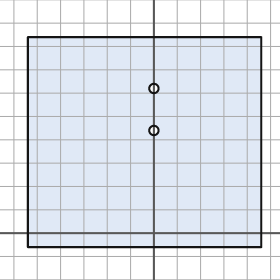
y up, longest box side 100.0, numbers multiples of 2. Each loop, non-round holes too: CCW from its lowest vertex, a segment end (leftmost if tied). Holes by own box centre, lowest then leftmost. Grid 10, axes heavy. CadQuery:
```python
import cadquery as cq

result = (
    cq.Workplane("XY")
    .moveTo(-54.0, -6.0)
    .lineTo(46.0, -6.0)
    .lineTo(46.0, 84.0)
    .lineTo(-54.0, 84.0)
    .close()
    .moveTo(0.0, 44.0)
    .circle(2.0)
    .moveTo(0.0, 62.0)
    .circle(2.0)
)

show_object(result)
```